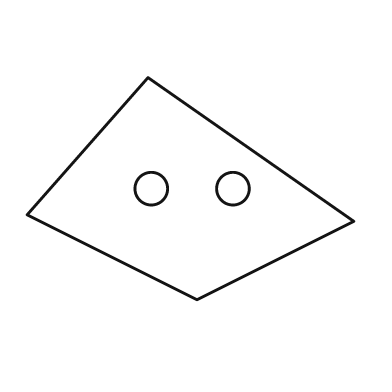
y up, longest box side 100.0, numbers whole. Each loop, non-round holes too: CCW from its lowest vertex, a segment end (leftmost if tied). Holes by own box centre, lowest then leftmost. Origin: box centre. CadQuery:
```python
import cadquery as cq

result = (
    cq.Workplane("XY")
    .moveTo(2.0, -34.0)
    .lineTo(50.0, -10.0)
    .lineTo(-13.0, 34.0)
    .lineTo(-50.0, -8.0)
    .close()
    .moveTo(-12.0, 0.0)
    .circle(5.0)
    .moveTo(13.0, 0.0)
    .circle(5.0)
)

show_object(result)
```